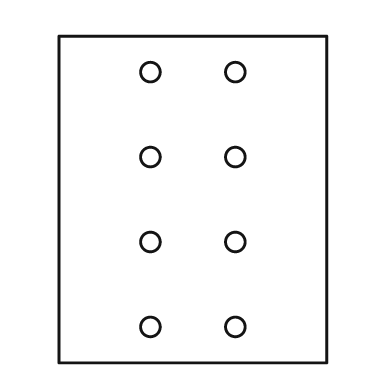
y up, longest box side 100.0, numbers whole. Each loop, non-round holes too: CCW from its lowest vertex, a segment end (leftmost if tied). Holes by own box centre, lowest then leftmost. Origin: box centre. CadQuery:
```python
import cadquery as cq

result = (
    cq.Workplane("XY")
    .moveTo(-41.0, -50.0)
    .lineTo(41.0, -50.0)
    .lineTo(41.0, 50.0)
    .lineTo(-41.0, 50.0)
    .close()
    .moveTo(-13.0, -39.0)
    .circle(3.0)
    .moveTo(13.0, -39.0)
    .circle(3.0)
    .moveTo(-13.0, -13.0)
    .circle(3.0)
    .moveTo(13.0, -13.0)
    .circle(3.0)
    .moveTo(-13.0, 13.0)
    .circle(3.0)
    .moveTo(13.0, 13.0)
    .circle(3.0)
    .moveTo(-13.0, 39.0)
    .circle(3.0)
    .moveTo(13.0, 39.0)
    .circle(3.0)
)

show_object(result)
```